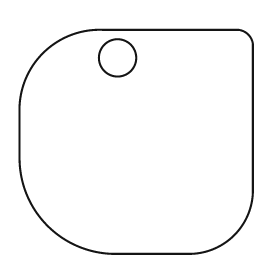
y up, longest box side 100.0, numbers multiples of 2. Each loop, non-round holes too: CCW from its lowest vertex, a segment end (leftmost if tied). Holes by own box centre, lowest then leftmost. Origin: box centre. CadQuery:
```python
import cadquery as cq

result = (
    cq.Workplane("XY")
    .moveTo(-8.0, -48.0)
    .lineTo(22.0, -48.0)
    .threePointArc((42.0, -40.0), (50.0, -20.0))
    .lineTo(50.0, 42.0)
    .threePointArc((48.0, 46.0), (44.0, 48.0))
    .lineTo(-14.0, 48.0)
    .threePointArc((-40.0, 38.0), (-50.0, 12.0))
    .lineTo(-50.0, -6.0)
    .threePointArc((-38.0, -36.0), (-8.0, -48.0))
    .close()
    .moveTo(-8.0, 36.0)
    .circle(8.0)
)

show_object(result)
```